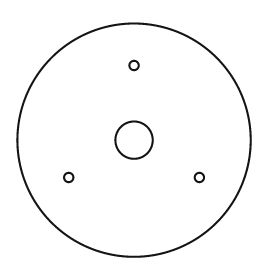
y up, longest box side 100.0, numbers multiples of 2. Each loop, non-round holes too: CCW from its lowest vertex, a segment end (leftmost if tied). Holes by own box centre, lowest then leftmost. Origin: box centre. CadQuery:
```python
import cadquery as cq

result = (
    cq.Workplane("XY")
    .moveTo(0.0, 0.0)
    .circle(50.0)
    .moveTo(-28.0, -16.0)
    .circle(2.0)
    .moveTo(28.0, -16.0)
    .circle(2.0)
    .moveTo(0.0, 0.0)
    .circle(8.0)
    .moveTo(0.0, 32.0)
    .circle(2.0)
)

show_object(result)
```